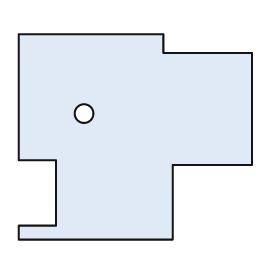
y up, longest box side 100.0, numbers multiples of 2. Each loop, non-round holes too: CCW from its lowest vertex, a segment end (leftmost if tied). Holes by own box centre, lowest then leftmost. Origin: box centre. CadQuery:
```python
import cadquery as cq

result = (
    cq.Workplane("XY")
    .moveTo(-50.0, -44.0)
    .lineTo(16.0, -44.0)
    .lineTo(16.0, -12.0)
    .lineTo(50.0, -12.0)
    .lineTo(50.0, 36.0)
    .lineTo(12.0, 36.0)
    .lineTo(12.0, 44.0)
    .lineTo(-50.0, 44.0)
    .lineTo(-50.0, -10.0)
    .lineTo(-34.0, -10.0)
    .lineTo(-34.0, -38.0)
    .lineTo(-50.0, -38.0)
    .close()
    .moveTo(-22.0, 10.0)
    .circle(4.0)
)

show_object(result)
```